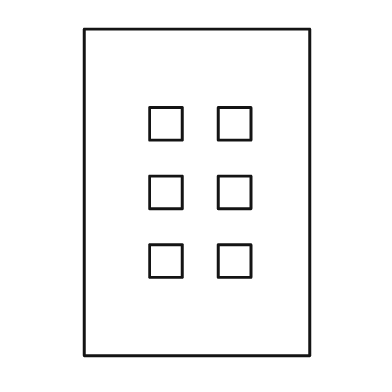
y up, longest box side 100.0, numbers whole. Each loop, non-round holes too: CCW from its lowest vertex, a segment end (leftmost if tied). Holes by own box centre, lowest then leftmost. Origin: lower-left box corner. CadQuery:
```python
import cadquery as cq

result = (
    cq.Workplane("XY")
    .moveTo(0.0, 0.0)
    .lineTo(69.0, 0.0)
    .lineTo(69.0, 100.0)
    .lineTo(0.0, 100.0)
    .close()
    .moveTo(20.0, 24.0)
    .lineTo(30.0, 24.0)
    .lineTo(30.0, 34.0)
    .lineTo(20.0, 34.0)
    .close()
    .moveTo(41.0, 24.0)
    .lineTo(51.0, 24.0)
    .lineTo(51.0, 34.0)
    .lineTo(41.0, 34.0)
    .close()
    .moveTo(20.0, 45.0)
    .lineTo(30.0, 45.0)
    .lineTo(30.0, 55.0)
    .lineTo(20.0, 55.0)
    .close()
    .moveTo(41.0, 45.0)
    .lineTo(51.0, 45.0)
    .lineTo(51.0, 55.0)
    .lineTo(41.0, 55.0)
    .close()
    .moveTo(20.0, 66.0)
    .lineTo(30.0, 66.0)
    .lineTo(30.0, 76.0)
    .lineTo(20.0, 76.0)
    .close()
    .moveTo(41.0, 66.0)
    .lineTo(51.0, 66.0)
    .lineTo(51.0, 76.0)
    .lineTo(41.0, 76.0)
    .close()
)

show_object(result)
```